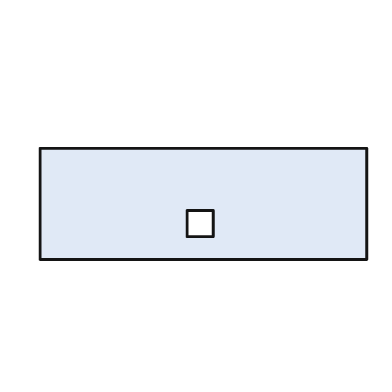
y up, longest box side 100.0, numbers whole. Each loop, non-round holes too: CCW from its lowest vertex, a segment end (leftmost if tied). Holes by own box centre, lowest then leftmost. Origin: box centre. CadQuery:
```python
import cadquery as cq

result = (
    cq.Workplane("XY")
    .moveTo(-50.0, -17.0)
    .lineTo(50.0, -17.0)
    .lineTo(50.0, 17.0)
    .lineTo(-50.0, 17.0)
    .close()
    .moveTo(-5.0, -10.0)
    .lineTo(3.0, -10.0)
    .lineTo(3.0, -2.0)
    .lineTo(-5.0, -2.0)
    .close()
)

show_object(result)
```